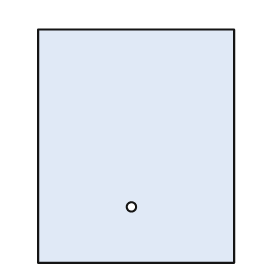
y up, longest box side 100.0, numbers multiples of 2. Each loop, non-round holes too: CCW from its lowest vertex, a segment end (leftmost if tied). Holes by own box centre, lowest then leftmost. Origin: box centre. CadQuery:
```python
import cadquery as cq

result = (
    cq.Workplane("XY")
    .moveTo(-42.0, -50.0)
    .lineTo(42.0, -50.0)
    .lineTo(42.0, 50.0)
    .lineTo(-42.0, 50.0)
    .close()
    .moveTo(-2.0, -26.0)
    .circle(2.0)
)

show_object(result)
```